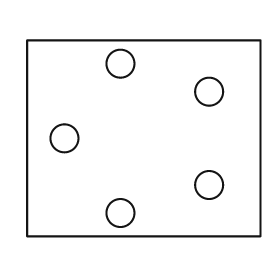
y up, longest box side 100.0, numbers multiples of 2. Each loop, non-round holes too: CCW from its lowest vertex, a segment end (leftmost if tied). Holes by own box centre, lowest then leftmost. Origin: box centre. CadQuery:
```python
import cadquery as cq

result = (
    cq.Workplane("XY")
    .moveTo(-50.0, -42.0)
    .lineTo(50.0, -42.0)
    .lineTo(50.0, 42.0)
    .lineTo(-50.0, 42.0)
    .close()
    .moveTo(-10.0, -32.0)
    .circle(6.0)
    .moveTo(28.0, -20.0)
    .circle(6.0)
    .moveTo(-34.0, 0.0)
    .circle(6.0)
    .moveTo(28.0, 20.0)
    .circle(6.0)
    .moveTo(-10.0, 32.0)
    .circle(6.0)
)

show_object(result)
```